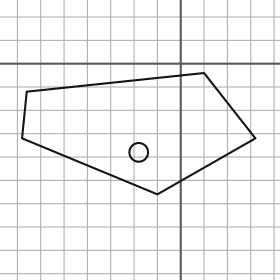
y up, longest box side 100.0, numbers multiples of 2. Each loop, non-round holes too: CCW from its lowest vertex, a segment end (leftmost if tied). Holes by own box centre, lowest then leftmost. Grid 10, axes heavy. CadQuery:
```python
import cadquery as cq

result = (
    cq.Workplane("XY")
    .moveTo(-10.0, -56.0)
    .lineTo(32.0, -32.0)
    .lineTo(10.0, -4.0)
    .lineTo(-66.0, -12.0)
    .lineTo(-68.0, -32.0)
    .close()
    .moveTo(-18.0, -38.0)
    .circle(4.0)
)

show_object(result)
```